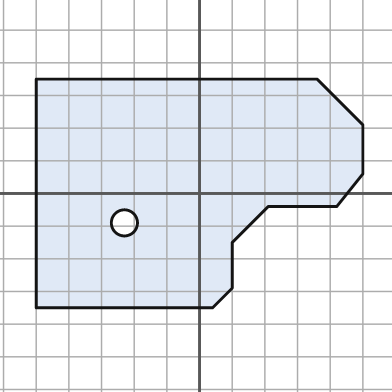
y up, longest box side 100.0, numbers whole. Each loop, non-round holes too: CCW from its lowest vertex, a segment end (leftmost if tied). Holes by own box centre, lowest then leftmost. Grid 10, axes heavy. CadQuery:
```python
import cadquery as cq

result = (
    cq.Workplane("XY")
    .moveTo(-50.0, -35.0)
    .lineTo(4.0, -35.0)
    .lineTo(10.0, -29.0)
    .lineTo(10.0, -15.0)
    .lineTo(21.0, -4.0)
    .lineTo(42.0, -4.0)
    .lineTo(50.0, 6.0)
    .lineTo(50.0, 21.0)
    .lineTo(36.0, 35.0)
    .lineTo(-50.0, 35.0)
    .close()
    .moveTo(-23.0, -9.0)
    .circle(4.0)
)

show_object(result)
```